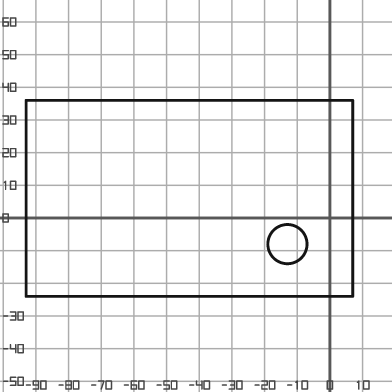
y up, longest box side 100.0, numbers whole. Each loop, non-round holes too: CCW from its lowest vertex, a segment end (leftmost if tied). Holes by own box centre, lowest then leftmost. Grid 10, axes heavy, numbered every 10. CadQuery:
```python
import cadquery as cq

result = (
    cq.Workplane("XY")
    .moveTo(-93.0, -24.0)
    .lineTo(7.0, -24.0)
    .lineTo(7.0, 36.0)
    .lineTo(-93.0, 36.0)
    .close()
    .moveTo(-13.0, -8.0)
    .circle(6.0)
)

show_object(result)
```